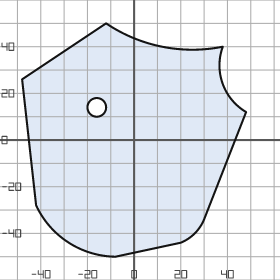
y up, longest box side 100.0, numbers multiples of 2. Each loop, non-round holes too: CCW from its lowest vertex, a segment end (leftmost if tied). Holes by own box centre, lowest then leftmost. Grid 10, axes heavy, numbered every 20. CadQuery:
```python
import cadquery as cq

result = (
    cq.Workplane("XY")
    .moveTo(-8.0, -50.0)
    .lineTo(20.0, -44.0)
    .threePointArc((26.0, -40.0), (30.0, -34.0))
    .lineTo(48.0, 12.0)
    .threePointArc((38.0, 24.0), (38.0, 40.0))
    .threePointArc((12.0, 40.0), (-12.0, 50.0))
    .lineTo(-48.0, 26.0)
    .lineTo(-42.0, -28.0)
    .threePointArc((-28.0, -44.0), (-8.0, -50.0))
    .close()
    .moveTo(-16.0, 14.0)
    .circle(4.0)
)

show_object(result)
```